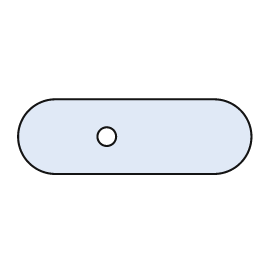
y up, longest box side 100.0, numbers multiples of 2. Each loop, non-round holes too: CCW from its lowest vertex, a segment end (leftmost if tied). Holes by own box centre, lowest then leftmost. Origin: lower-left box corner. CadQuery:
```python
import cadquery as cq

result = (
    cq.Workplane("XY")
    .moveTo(16.0, 0.0)
    .lineTo(84.0, 0.0)
    .threePointArc((100.0, 16.0), (84.0, 32.0))
    .lineTo(16.0, 32.0)
    .threePointArc((0.0, 16.0), (16.0, 0.0))
    .close()
    .moveTo(38.0, 16.0)
    .circle(4.0)
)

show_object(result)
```